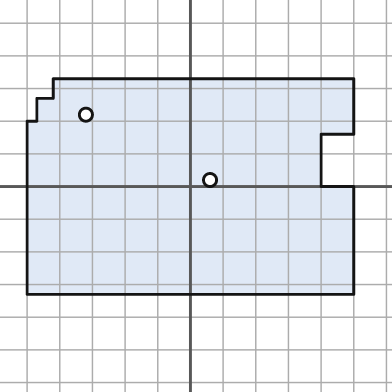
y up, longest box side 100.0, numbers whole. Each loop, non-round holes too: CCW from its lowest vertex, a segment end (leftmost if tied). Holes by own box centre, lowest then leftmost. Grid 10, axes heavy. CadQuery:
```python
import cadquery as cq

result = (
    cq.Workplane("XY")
    .moveTo(-50.0, -33.0)
    .lineTo(50.0, -33.0)
    .lineTo(50.0, 0.0)
    .lineTo(40.0, 0.0)
    .lineTo(40.0, 16.0)
    .lineTo(50.0, 16.0)
    .lineTo(50.0, 33.0)
    .lineTo(-42.0, 33.0)
    .lineTo(-42.0, 27.0)
    .lineTo(-47.0, 27.0)
    .lineTo(-47.0, 20.0)
    .lineTo(-50.0, 20.0)
    .close()
    .moveTo(6.0, 2.0)
    .circle(2.0)
    .moveTo(-32.0, 22.0)
    .circle(2.0)
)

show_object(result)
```